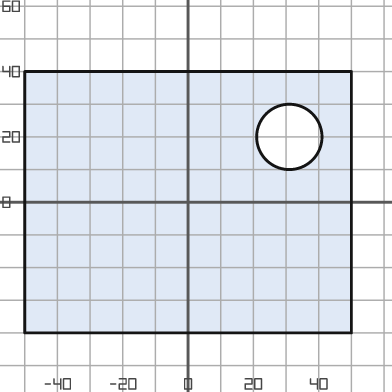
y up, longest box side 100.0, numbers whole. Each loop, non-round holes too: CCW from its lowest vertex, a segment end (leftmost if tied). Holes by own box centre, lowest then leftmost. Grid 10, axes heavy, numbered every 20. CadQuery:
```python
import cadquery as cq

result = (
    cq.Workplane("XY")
    .moveTo(-50.0, -40.0)
    .lineTo(50.0, -40.0)
    .lineTo(50.0, 40.0)
    .lineTo(-50.0, 40.0)
    .close()
    .moveTo(31.0, 20.0)
    .circle(10.0)
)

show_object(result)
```